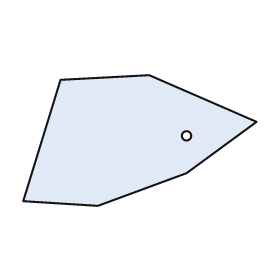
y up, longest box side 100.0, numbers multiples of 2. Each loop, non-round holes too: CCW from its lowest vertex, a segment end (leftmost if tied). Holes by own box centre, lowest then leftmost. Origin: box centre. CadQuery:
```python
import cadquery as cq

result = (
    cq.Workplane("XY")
    .moveTo(-18.0, -28.0)
    .lineTo(20.0, -14.0)
    .lineTo(50.0, 8.0)
    .lineTo(4.0, 28.0)
    .lineTo(-34.0, 26.0)
    .lineTo(-50.0, -26.0)
    .close()
    .moveTo(20.0, 2.0)
    .circle(2.0)
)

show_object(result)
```